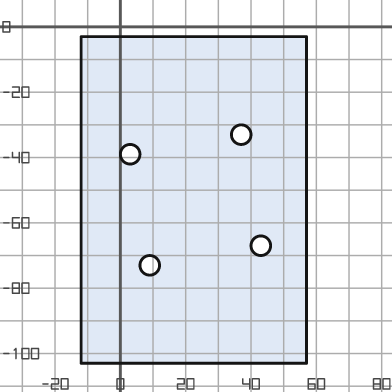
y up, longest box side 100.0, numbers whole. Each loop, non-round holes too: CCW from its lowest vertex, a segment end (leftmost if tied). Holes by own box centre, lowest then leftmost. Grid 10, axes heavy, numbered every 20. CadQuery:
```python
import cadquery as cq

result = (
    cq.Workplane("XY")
    .moveTo(-12.0, -103.0)
    .lineTo(57.0, -103.0)
    .lineTo(57.0, -3.0)
    .lineTo(-12.0, -3.0)
    .close()
    .moveTo(9.0, -73.0)
    .circle(3.0)
    .moveTo(43.0, -67.0)
    .circle(3.0)
    .moveTo(3.0, -39.0)
    .circle(3.0)
    .moveTo(37.0, -33.0)
    .circle(3.0)
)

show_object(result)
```